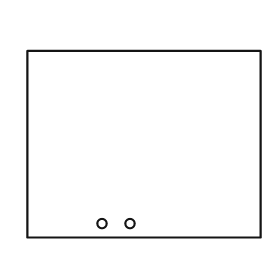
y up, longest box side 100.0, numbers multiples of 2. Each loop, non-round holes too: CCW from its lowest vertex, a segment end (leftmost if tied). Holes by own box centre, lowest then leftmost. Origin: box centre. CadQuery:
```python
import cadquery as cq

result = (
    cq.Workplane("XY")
    .moveTo(-50.0, -40.0)
    .lineTo(50.0, -40.0)
    .lineTo(50.0, 40.0)
    .lineTo(-50.0, 40.0)
    .close()
    .moveTo(-18.0, -34.0)
    .circle(2.0)
    .moveTo(-6.0, -34.0)
    .circle(2.0)
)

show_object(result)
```